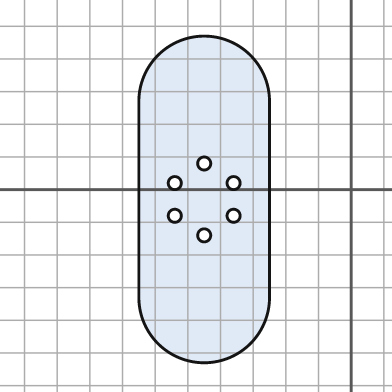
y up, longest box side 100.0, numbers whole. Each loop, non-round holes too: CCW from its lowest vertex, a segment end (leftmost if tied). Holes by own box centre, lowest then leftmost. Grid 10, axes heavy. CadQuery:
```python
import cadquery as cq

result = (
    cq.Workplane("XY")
    .moveTo(-65.0, -33.0)
    .threePointArc((-45.0, -53.0), (-25.0, -33.0))
    .lineTo(-25.0, 27.0)
    .threePointArc((-45.0, 47.0), (-65.0, 27.0))
    .close()
    .moveTo(-45.0, -14.0)
    .circle(2.0)
    .moveTo(-54.0, -8.0)
    .circle(2.0)
    .moveTo(-36.0, -8.0)
    .circle(2.0)
    .moveTo(-54.0, 2.0)
    .circle(2.0)
    .moveTo(-36.0, 2.0)
    .circle(2.0)
    .moveTo(-45.0, 8.0)
    .circle(2.0)
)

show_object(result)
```